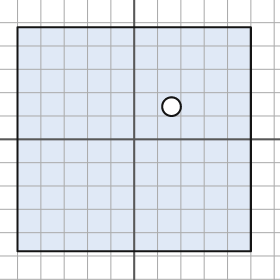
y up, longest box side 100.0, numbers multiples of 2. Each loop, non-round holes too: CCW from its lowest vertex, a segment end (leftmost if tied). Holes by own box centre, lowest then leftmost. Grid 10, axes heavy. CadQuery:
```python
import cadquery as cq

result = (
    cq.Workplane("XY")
    .moveTo(-50.0, -48.0)
    .lineTo(50.0, -48.0)
    .lineTo(50.0, 48.0)
    .lineTo(-50.0, 48.0)
    .close()
    .moveTo(16.0, 14.0)
    .circle(4.0)
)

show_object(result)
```